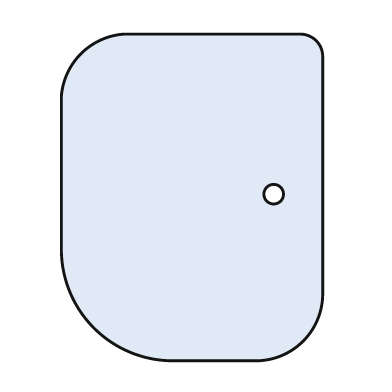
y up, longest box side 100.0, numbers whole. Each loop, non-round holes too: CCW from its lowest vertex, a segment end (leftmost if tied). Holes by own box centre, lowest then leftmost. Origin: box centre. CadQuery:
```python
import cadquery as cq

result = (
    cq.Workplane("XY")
    .moveTo(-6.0, -50.0)
    .lineTo(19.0, -50.0)
    .threePointArc((34.0, -44.0), (40.0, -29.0))
    .lineTo(40.0, 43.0)
    .threePointArc((38.0, 48.0), (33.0, 50.0))
    .lineTo(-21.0, 50.0)
    .threePointArc((-34.0, 44.0), (-40.0, 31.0))
    .lineTo(-40.0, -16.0)
    .threePointArc((-30.0, -40.0), (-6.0, -50.0))
    .close()
    .moveTo(25.0, 1.0)
    .circle(3.0)
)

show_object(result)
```